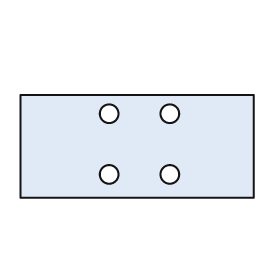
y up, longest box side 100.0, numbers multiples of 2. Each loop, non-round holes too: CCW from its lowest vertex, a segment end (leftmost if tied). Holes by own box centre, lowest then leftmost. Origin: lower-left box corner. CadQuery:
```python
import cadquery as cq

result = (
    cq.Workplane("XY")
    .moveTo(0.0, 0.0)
    .lineTo(100.0, 0.0)
    .lineTo(100.0, 44.0)
    .lineTo(0.0, 44.0)
    .close()
    .moveTo(38.0, 10.0)
    .circle(4.0)
    .moveTo(64.0, 10.0)
    .circle(4.0)
    .moveTo(38.0, 36.0)
    .circle(4.0)
    .moveTo(64.0, 36.0)
    .circle(4.0)
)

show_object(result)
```